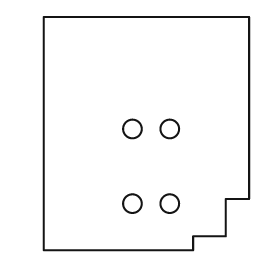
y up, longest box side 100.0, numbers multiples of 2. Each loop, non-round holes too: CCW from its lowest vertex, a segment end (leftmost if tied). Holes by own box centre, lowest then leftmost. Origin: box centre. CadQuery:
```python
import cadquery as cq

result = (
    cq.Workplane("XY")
    .moveTo(-44.0, -50.0)
    .lineTo(20.0, -50.0)
    .lineTo(20.0, -44.0)
    .lineTo(34.0, -44.0)
    .lineTo(34.0, -28.0)
    .lineTo(44.0, -28.0)
    .lineTo(44.0, 50.0)
    .lineTo(-44.0, 50.0)
    .close()
    .moveTo(-6.0, -30.0)
    .circle(4.0)
    .moveTo(10.0, -30.0)
    .circle(4.0)
    .moveTo(-6.0, 2.0)
    .circle(4.0)
    .moveTo(10.0, 2.0)
    .circle(4.0)
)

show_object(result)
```